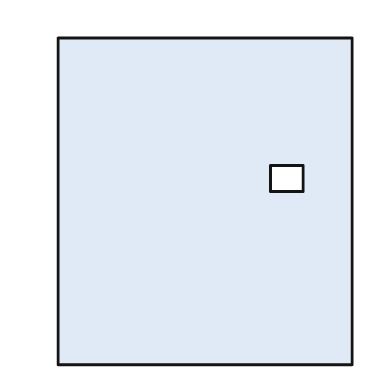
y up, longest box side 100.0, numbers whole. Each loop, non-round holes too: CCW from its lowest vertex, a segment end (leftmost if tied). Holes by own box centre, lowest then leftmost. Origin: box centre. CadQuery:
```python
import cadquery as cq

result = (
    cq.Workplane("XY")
    .moveTo(-45.0, -50.0)
    .lineTo(45.0, -50.0)
    .lineTo(45.0, 50.0)
    .lineTo(-45.0, 50.0)
    .close()
    .moveTo(20.0, 3.0)
    .lineTo(30.0, 3.0)
    .lineTo(30.0, 11.0)
    .lineTo(20.0, 11.0)
    .close()
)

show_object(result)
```